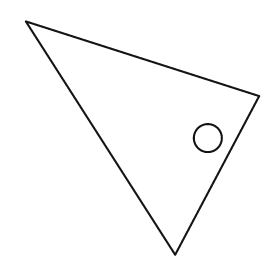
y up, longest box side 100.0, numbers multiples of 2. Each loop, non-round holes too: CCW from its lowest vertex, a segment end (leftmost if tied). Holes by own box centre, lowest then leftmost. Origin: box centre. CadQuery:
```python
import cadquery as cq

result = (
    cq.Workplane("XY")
    .moveTo(14.0, -50.0)
    .lineTo(50.0, 18.0)
    .lineTo(-50.0, 50.0)
    .close()
    .moveTo(28.0, 0.0)
    .circle(6.0)
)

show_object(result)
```